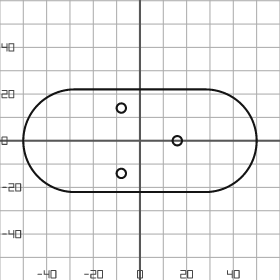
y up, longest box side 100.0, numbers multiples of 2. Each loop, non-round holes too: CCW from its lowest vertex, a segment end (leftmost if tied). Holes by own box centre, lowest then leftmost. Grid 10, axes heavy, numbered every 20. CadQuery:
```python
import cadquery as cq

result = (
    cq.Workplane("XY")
    .moveTo(-28.0, -22.0)
    .lineTo(28.0, -22.0)
    .threePointArc((50.0, 0.0), (28.0, 22.0))
    .lineTo(-28.0, 22.0)
    .threePointArc((-50.0, 0.0), (-28.0, -22.0))
    .close()
    .moveTo(-8.0, -14.0)
    .circle(2.0)
    .moveTo(16.0, 0.0)
    .circle(2.0)
    .moveTo(-8.0, 14.0)
    .circle(2.0)
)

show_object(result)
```